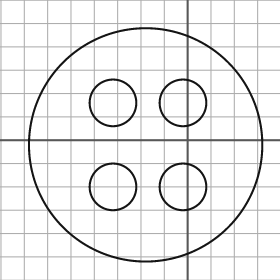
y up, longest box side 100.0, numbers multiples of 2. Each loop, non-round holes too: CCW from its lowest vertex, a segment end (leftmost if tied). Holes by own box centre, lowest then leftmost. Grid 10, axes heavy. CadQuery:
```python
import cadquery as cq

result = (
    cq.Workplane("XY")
    .moveTo(-18.0, -2.0)
    .circle(50.0)
    .moveTo(-32.0, -20.0)
    .circle(10.0)
    .moveTo(-2.0, -20.0)
    .circle(10.0)
    .moveTo(-32.0, 16.0)
    .circle(10.0)
    .moveTo(-2.0, 16.0)
    .circle(10.0)
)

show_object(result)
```